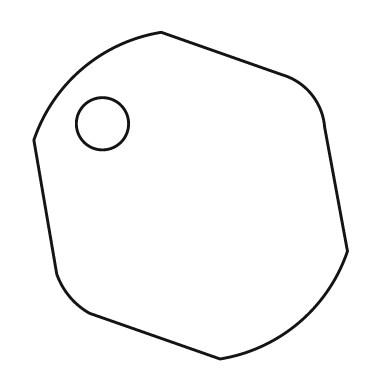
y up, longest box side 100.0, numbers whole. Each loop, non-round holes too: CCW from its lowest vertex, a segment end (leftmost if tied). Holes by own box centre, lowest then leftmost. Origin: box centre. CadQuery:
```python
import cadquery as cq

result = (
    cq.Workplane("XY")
    .moveTo(9.0, -50.0)
    .threePointArc((33.0, -39.0), (48.0, -17.0))
    .lineTo(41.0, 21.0)
    .threePointArc((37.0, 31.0), (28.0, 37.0))
    .lineTo(-9.0, 50.0)
    .threePointArc((-33.0, 39.0), (-48.0, 17.0))
    .lineTo(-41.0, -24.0)
    .threePointArc((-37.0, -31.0), (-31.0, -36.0))
    .close()
    .moveTo(-27.0, 22.0)
    .circle(8.0)
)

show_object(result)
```